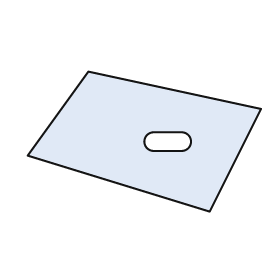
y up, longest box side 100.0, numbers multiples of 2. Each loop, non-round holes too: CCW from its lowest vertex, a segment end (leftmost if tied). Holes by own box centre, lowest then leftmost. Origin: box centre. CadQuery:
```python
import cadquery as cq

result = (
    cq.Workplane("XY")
    .moveTo(28.0, -30.0)
    .lineTo(50.0, 14.0)
    .lineTo(-24.0, 30.0)
    .lineTo(-50.0, -6.0)
    .close()
    .moveTo(4.0, -4.0)
    .lineTo(16.0, -4.0)
    .threePointArc((20.0, 0.0), (16.0, 4.0))
    .lineTo(4.0, 4.0)
    .threePointArc((0.0, 0.0), (4.0, -4.0))
    .close()
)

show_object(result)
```